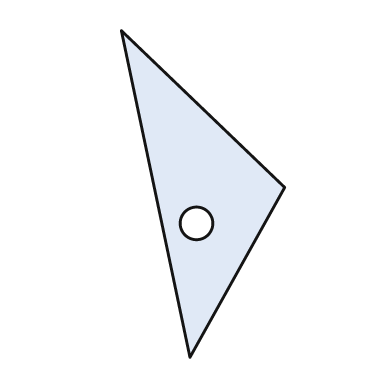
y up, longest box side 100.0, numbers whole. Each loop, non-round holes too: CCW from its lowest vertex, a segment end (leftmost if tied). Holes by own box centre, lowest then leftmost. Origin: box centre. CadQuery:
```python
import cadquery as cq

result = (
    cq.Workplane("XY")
    .moveTo(-4.0, -50.0)
    .lineTo(25.0, 2.0)
    .lineTo(-25.0, 50.0)
    .close()
    .moveTo(-2.0, -9.0)
    .circle(5.0)
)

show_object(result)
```